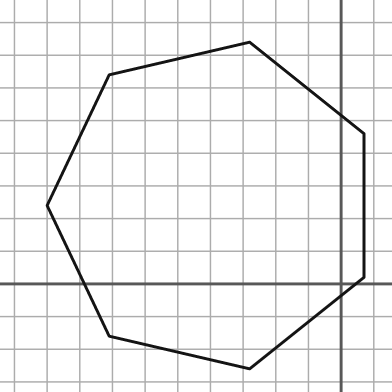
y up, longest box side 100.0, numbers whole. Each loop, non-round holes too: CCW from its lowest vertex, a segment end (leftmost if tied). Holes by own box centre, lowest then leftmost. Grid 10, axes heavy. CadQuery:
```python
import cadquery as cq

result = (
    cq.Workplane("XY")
    .moveTo(-28.0, -26.0)
    .lineTo(7.0, 2.0)
    .lineTo(7.0, 46.0)
    .lineTo(-28.0, 74.0)
    .lineTo(-71.0, 64.0)
    .lineTo(-90.0, 24.0)
    .lineTo(-71.0, -16.0)
    .close()
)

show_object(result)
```